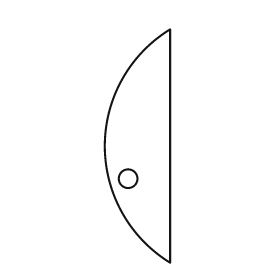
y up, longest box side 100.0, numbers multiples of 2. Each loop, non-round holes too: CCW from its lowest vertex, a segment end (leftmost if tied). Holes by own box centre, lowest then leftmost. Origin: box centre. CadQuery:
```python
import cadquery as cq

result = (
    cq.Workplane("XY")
    .moveTo(14.0, -50.0)
    .lineTo(14.0, 50.0)
    .threePointArc((-14.0, 0.0), (14.0, -50.0))
    .close()
    .moveTo(-4.0, -14.0)
    .circle(4.0)
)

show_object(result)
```